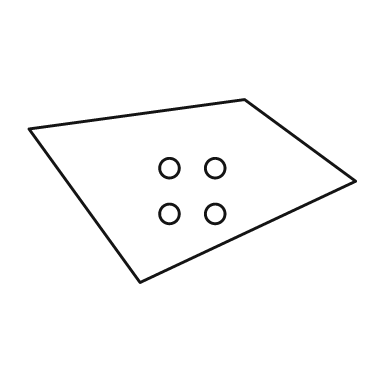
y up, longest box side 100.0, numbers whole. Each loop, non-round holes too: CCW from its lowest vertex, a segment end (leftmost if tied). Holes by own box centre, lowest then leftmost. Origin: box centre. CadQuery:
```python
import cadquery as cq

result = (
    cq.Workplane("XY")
    .moveTo(-16.0, -28.0)
    .lineTo(50.0, 3.0)
    .lineTo(16.0, 28.0)
    .lineTo(-50.0, 19.0)
    .close()
    .moveTo(-7.0, -7.0)
    .circle(3.0)
    .moveTo(7.0, -7.0)
    .circle(3.0)
    .moveTo(-7.0, 7.0)
    .circle(3.0)
    .moveTo(7.0, 7.0)
    .circle(3.0)
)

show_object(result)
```